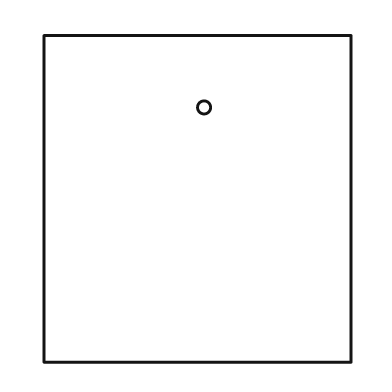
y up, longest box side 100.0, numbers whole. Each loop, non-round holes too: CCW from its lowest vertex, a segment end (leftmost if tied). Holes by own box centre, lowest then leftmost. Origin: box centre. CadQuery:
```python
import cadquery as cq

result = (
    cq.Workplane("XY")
    .moveTo(-47.0, -50.0)
    .lineTo(47.0, -50.0)
    .lineTo(47.0, 50.0)
    .lineTo(-47.0, 50.0)
    .close()
    .moveTo(2.0, 28.0)
    .circle(2.0)
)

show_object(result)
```